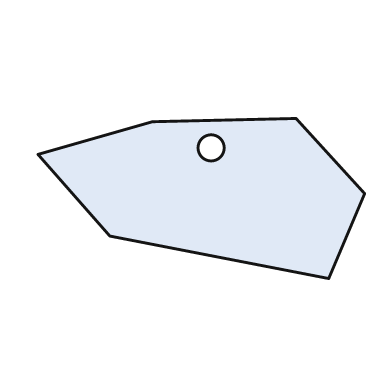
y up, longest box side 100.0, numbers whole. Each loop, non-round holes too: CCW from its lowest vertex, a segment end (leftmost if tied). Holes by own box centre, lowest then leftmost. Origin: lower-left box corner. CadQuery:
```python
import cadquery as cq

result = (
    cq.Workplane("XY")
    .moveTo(89.0, 0.0)
    .lineTo(100.0, 26.0)
    .lineTo(79.0, 49.0)
    .lineTo(35.0, 48.0)
    .lineTo(0.0, 38.0)
    .lineTo(22.0, 13.0)
    .close()
    .moveTo(53.0, 40.0)
    .circle(4.0)
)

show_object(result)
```